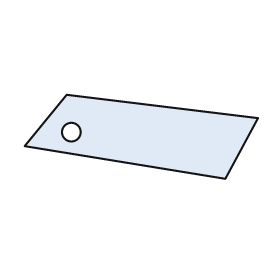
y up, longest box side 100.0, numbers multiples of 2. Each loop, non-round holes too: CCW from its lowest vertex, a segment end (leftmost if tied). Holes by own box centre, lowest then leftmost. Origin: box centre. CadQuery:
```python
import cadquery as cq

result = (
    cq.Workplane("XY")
    .moveTo(36.0, -18.0)
    .lineTo(50.0, 8.0)
    .lineTo(-32.0, 18.0)
    .lineTo(-50.0, -4.0)
    .close()
    .moveTo(-30.0, 2.0)
    .circle(4.0)
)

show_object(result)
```